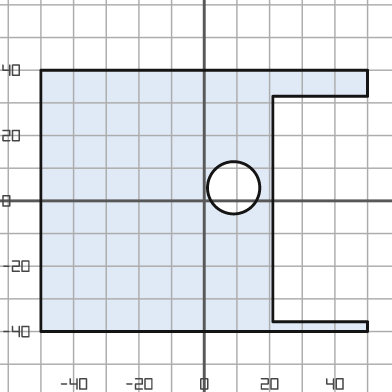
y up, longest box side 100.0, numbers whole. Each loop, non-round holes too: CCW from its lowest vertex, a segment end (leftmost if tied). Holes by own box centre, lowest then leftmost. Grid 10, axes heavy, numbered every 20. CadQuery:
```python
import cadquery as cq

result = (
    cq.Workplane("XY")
    .moveTo(-50.0, -40.0)
    .lineTo(50.0, -40.0)
    .lineTo(50.0, -37.0)
    .lineTo(21.0, -37.0)
    .lineTo(21.0, 32.0)
    .lineTo(50.0, 32.0)
    .lineTo(50.0, 40.0)
    .lineTo(-50.0, 40.0)
    .close()
    .moveTo(9.0, 4.0)
    .circle(8.0)
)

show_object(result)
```